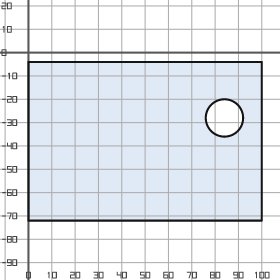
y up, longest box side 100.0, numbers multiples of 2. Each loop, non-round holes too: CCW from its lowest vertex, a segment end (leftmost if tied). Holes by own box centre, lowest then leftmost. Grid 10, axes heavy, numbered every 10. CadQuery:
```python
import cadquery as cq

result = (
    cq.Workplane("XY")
    .moveTo(0.0, -72.0)
    .lineTo(100.0, -72.0)
    .lineTo(100.0, -4.0)
    .lineTo(0.0, -4.0)
    .close()
    .moveTo(84.0, -28.0)
    .circle(8.0)
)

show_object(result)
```